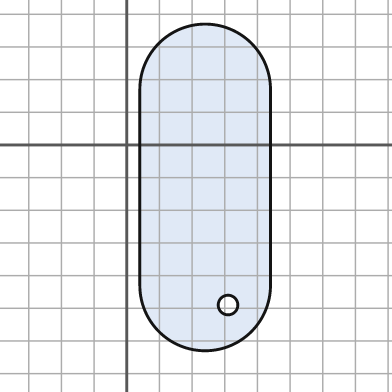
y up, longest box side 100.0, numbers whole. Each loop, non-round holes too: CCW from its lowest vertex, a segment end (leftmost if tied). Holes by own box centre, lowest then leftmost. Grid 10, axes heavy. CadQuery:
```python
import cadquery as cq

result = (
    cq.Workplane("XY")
    .moveTo(4.0, -43.0)
    .threePointArc((24.0, -63.0), (44.0, -43.0))
    .lineTo(44.0, 17.0)
    .threePointArc((24.0, 37.0), (4.0, 17.0))
    .close()
    .moveTo(31.0, -49.0)
    .circle(3.0)
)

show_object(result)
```